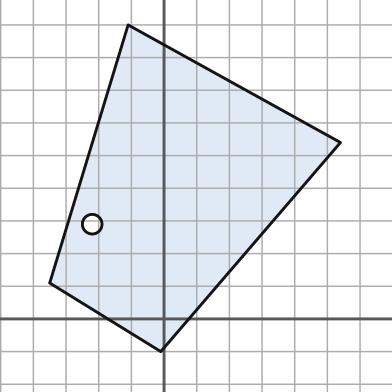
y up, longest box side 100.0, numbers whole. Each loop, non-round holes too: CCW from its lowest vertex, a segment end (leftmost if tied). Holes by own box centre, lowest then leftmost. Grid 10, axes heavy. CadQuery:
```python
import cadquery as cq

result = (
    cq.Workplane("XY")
    .moveTo(-1.0, -10.0)
    .lineTo(54.0, 54.0)
    .lineTo(-11.0, 90.0)
    .lineTo(-35.0, 11.0)
    .close()
    .moveTo(-22.0, 29.0)
    .circle(3.0)
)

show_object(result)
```